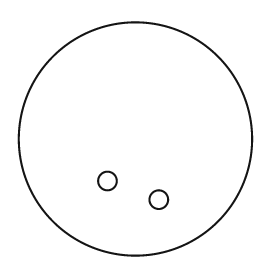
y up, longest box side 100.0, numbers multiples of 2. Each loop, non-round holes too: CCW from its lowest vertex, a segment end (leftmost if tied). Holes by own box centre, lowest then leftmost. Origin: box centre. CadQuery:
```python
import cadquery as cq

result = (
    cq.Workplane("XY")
    .moveTo(0.0, 0.0)
    .circle(50.0)
    .moveTo(10.0, -26.0)
    .circle(4.0)
    .moveTo(-12.0, -18.0)
    .circle(4.0)
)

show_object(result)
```